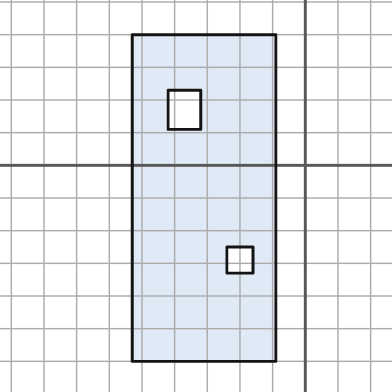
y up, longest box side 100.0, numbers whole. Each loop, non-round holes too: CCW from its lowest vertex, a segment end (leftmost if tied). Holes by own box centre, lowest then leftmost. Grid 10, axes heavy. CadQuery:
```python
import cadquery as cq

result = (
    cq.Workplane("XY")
    .moveTo(-53.0, -60.0)
    .lineTo(-9.0, -60.0)
    .lineTo(-9.0, 40.0)
    .lineTo(-53.0, 40.0)
    .close()
    .moveTo(-24.0, -33.0)
    .lineTo(-16.0, -33.0)
    .lineTo(-16.0, -25.0)
    .lineTo(-24.0, -25.0)
    .close()
    .moveTo(-42.0, 11.0)
    .lineTo(-32.0, 11.0)
    .lineTo(-32.0, 23.0)
    .lineTo(-42.0, 23.0)
    .close()
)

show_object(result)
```